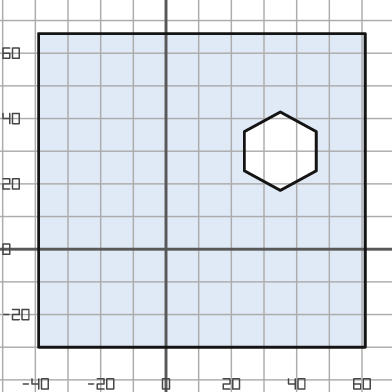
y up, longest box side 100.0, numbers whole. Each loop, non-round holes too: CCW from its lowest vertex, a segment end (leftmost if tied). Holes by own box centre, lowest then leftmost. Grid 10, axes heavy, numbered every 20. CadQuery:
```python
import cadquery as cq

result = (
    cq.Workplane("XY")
    .moveTo(-39.0, -30.0)
    .lineTo(61.0, -30.0)
    .lineTo(61.0, 66.0)
    .lineTo(-39.0, 66.0)
    .close()
    .moveTo(35.0, 18.0)
    .lineTo(46.0, 24.0)
    .lineTo(46.0, 36.0)
    .lineTo(35.0, 42.0)
    .lineTo(24.0, 36.0)
    .lineTo(24.0, 24.0)
    .close()
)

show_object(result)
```